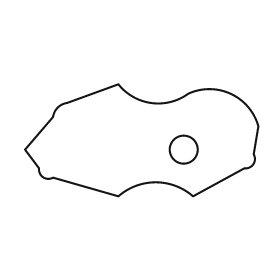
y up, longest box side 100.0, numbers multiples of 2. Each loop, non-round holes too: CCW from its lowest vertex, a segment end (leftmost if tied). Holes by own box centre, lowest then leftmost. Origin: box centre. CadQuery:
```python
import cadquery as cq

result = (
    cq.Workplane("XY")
    .moveTo(-10.0, -24.0)
    .threePointArc((6.0, -18.0), (22.0, -24.0))
    .lineTo(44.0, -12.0)
    .threePointArc((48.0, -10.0), (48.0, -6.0))
    .lineTo(50.0, 6.0)
    .threePointArc((38.0, 20.0), (20.0, 20.0))
    .threePointArc((4.0, 16.0), (-10.0, 24.0))
    .lineTo(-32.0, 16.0)
    .threePointArc((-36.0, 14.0), (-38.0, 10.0))
    .lineTo(-50.0, -4.0)
    .lineTo(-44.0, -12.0)
    .threePointArc((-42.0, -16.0), (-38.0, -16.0))
    .close()
    .moveTo(18.0, -4.0)
    .circle(6.0)
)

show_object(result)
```